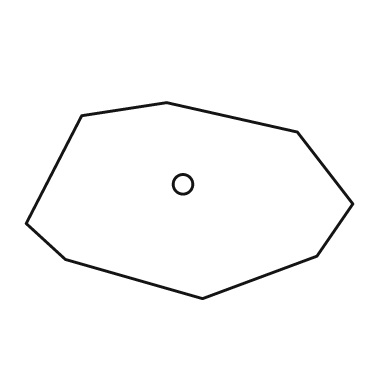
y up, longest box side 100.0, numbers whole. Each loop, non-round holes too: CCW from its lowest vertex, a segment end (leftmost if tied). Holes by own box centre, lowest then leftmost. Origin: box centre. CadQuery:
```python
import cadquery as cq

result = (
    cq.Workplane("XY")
    .moveTo(4.0, -30.0)
    .lineTo(39.0, -17.0)
    .lineTo(50.0, -1.0)
    .lineTo(33.0, 21.0)
    .lineTo(-7.0, 30.0)
    .lineTo(-33.0, 26.0)
    .lineTo(-50.0, -7.0)
    .lineTo(-38.0, -18.0)
    .close()
    .moveTo(-2.0, 5.0)
    .circle(3.0)
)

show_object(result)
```